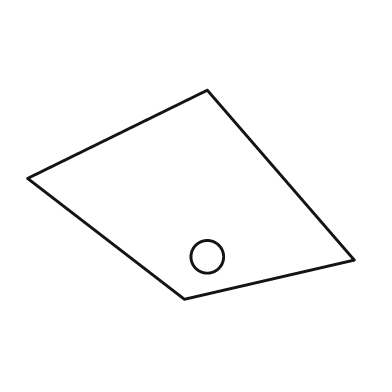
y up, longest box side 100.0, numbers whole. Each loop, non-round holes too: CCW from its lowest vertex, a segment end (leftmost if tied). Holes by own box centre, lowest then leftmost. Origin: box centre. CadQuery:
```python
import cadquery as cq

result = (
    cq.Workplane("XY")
    .moveTo(-2.0, -32.0)
    .lineTo(50.0, -20.0)
    .lineTo(5.0, 32.0)
    .lineTo(-50.0, 5.0)
    .close()
    .moveTo(5.0, -19.0)
    .circle(5.0)
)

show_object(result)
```